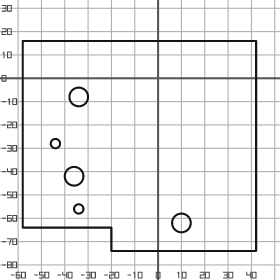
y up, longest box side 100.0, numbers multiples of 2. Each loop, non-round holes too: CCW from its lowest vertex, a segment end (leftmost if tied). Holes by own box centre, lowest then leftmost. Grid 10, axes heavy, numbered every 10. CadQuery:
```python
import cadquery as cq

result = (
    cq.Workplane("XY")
    .moveTo(-20.0, -74.0)
    .lineTo(42.0, -74.0)
    .lineTo(42.0, 16.0)
    .lineTo(-58.0, 16.0)
    .lineTo(-58.0, -64.0)
    .lineTo(-20.0, -64.0)
    .close()
    .moveTo(10.0, -62.0)
    .circle(4.0)
    .moveTo(-34.0, -56.0)
    .circle(2.0)
    .moveTo(-36.0, -42.0)
    .circle(4.0)
    .moveTo(-44.0, -28.0)
    .circle(2.0)
    .moveTo(-34.0, -8.0)
    .circle(4.0)
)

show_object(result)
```